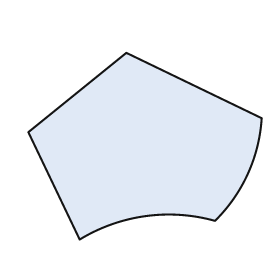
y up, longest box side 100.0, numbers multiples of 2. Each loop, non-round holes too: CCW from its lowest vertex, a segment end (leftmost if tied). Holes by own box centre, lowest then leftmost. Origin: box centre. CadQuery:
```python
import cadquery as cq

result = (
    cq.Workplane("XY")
    .moveTo(-28.0, -40.0)
    .threePointArc((0.0, -30.0), (30.0, -32.0))
    .threePointArc((44.0, -12.0), (50.0, 12.0))
    .lineTo(-8.0, 40.0)
    .lineTo(-50.0, 6.0)
    .close()
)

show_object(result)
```